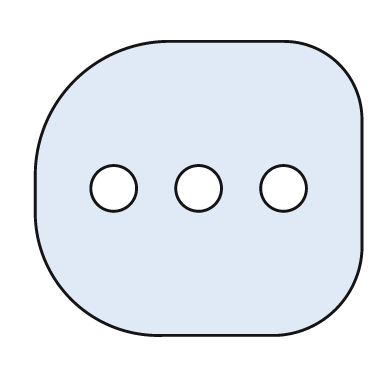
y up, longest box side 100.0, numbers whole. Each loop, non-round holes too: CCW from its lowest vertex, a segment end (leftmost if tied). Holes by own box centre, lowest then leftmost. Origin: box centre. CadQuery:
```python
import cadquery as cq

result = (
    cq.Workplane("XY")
    .moveTo(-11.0, -45.0)
    .lineTo(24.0, -45.0)
    .threePointArc((42.0, -37.0), (50.0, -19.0))
    .lineTo(50.0, 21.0)
    .threePointArc((43.0, 38.0), (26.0, 45.0))
    .lineTo(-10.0, 45.0)
    .threePointArc((-38.0, 33.0), (-50.0, 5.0))
    .lineTo(-50.0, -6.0)
    .threePointArc((-39.0, -34.0), (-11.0, -45.0))
    .close()
    .moveTo(-26.0, 0.0)
    .circle(7.0)
    .moveTo(0.0, 0.0)
    .circle(7.0)
    .moveTo(26.0, 0.0)
    .circle(7.0)
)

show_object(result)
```